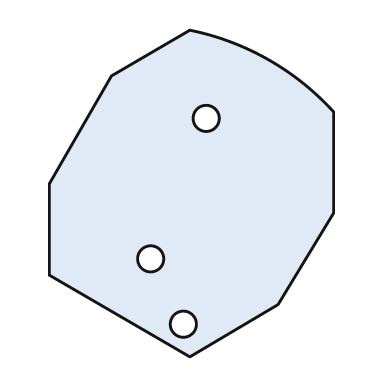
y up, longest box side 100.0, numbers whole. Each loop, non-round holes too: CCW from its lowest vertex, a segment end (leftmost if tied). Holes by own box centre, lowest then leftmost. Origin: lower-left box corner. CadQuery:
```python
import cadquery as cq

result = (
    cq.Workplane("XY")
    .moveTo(43.0, 0.0)
    .lineTo(70.0, 16.0)
    .lineTo(87.0, 44.0)
    .lineTo(87.0, 75.0)
    .threePointArc((67.0, 91.0), (43.0, 100.0))
    .lineTo(19.0, 86.0)
    .lineTo(0.0, 53.0)
    .lineTo(0.0, 25.0)
    .close()
    .moveTo(41.0, 10.0)
    .circle(4.0)
    .moveTo(31.0, 30.0)
    .circle(4.0)
    .moveTo(48.0, 73.0)
    .circle(4.0)
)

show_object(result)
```